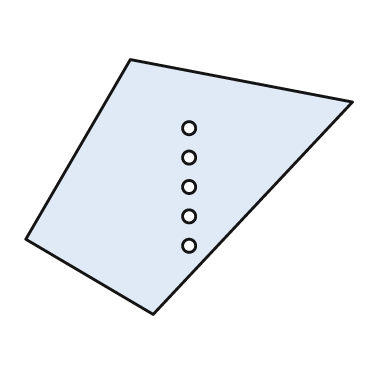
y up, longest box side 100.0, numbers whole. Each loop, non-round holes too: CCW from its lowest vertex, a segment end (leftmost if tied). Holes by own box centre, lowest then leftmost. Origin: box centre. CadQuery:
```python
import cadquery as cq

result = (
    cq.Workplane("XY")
    .moveTo(-11.0, -39.0)
    .lineTo(50.0, 26.0)
    .lineTo(-18.0, 39.0)
    .lineTo(-50.0, -16.0)
    .close()
    .moveTo(0.0, -18.0)
    .circle(2.0)
    .moveTo(0.0, -9.0)
    .circle(2.0)
    .moveTo(0.0, 0.0)
    .circle(2.0)
    .moveTo(0.0, 9.0)
    .circle(2.0)
    .moveTo(0.0, 18.0)
    .circle(2.0)
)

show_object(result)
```